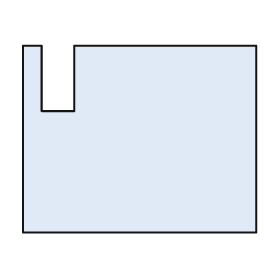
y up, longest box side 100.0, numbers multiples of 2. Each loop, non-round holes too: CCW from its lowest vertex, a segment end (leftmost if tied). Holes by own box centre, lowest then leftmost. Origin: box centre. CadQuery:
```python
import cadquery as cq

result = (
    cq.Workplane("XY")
    .moveTo(-50.0, -40.0)
    .lineTo(50.0, -40.0)
    .lineTo(50.0, 40.0)
    .lineTo(-28.0, 40.0)
    .lineTo(-28.0, 12.0)
    .lineTo(-42.0, 12.0)
    .lineTo(-42.0, 40.0)
    .lineTo(-50.0, 40.0)
    .close()
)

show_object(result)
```